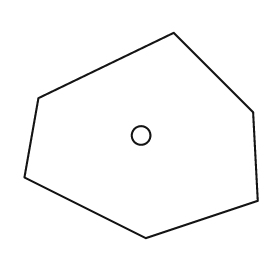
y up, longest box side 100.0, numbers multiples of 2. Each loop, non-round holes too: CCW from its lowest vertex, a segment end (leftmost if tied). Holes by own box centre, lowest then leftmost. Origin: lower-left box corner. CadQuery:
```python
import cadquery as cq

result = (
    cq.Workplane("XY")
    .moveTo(52.0, 0.0)
    .lineTo(100.0, 16.0)
    .lineTo(98.0, 54.0)
    .lineTo(64.0, 88.0)
    .lineTo(6.0, 60.0)
    .lineTo(0.0, 26.0)
    .close()
    .moveTo(50.0, 44.0)
    .circle(4.0)
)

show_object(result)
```